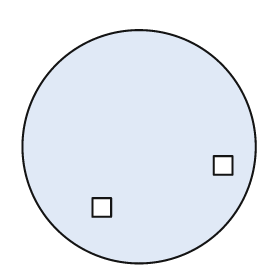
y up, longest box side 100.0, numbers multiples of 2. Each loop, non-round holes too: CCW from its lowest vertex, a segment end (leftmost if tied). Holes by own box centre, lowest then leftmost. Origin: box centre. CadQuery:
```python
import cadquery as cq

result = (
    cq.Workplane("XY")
    .moveTo(0.0, 0.0)
    .circle(50.0)
    .moveTo(-20.0, -30.0)
    .lineTo(-12.0, -30.0)
    .lineTo(-12.0, -22.0)
    .lineTo(-20.0, -22.0)
    .close()
    .moveTo(32.0, -12.0)
    .lineTo(40.0, -12.0)
    .lineTo(40.0, -4.0)
    .lineTo(32.0, -4.0)
    .close()
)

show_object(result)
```